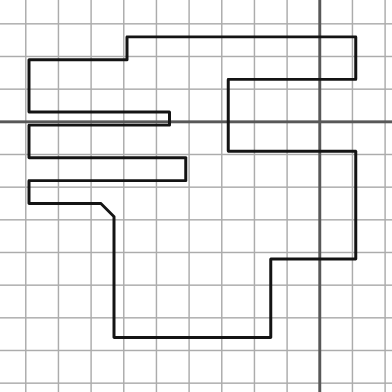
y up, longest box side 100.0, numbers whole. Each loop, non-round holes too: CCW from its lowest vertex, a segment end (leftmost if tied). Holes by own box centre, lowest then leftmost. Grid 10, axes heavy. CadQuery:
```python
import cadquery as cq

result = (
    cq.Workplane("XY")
    .moveTo(-63.0, -66.0)
    .lineTo(-15.0, -66.0)
    .lineTo(-15.0, -42.0)
    .lineTo(11.0, -42.0)
    .lineTo(11.0, -9.0)
    .lineTo(-28.0, -9.0)
    .lineTo(-28.0, 13.0)
    .lineTo(11.0, 13.0)
    .lineTo(11.0, 26.0)
    .lineTo(-59.0, 26.0)
    .lineTo(-59.0, 19.0)
    .lineTo(-89.0, 19.0)
    .lineTo(-89.0, 3.0)
    .lineTo(-46.0, 3.0)
    .lineTo(-46.0, -1.0)
    .lineTo(-89.0, -1.0)
    .lineTo(-89.0, -11.0)
    .lineTo(-41.0, -11.0)
    .lineTo(-41.0, -18.0)
    .lineTo(-89.0, -18.0)
    .lineTo(-89.0, -25.0)
    .lineTo(-67.0, -25.0)
    .lineTo(-63.0, -29.0)
    .close()
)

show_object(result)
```